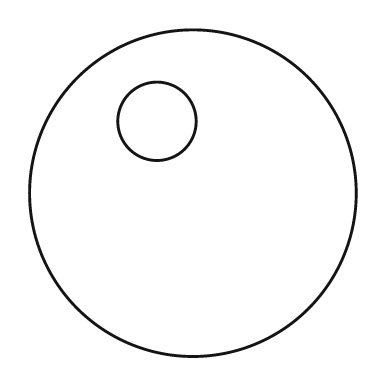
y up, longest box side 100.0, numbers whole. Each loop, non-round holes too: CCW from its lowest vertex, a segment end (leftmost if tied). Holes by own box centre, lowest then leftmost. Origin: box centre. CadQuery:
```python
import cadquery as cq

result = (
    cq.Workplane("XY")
    .moveTo(0.0, 0.0)
    .circle(50.0)
    .moveTo(-11.0, 22.0)
    .circle(12.0)
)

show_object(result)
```